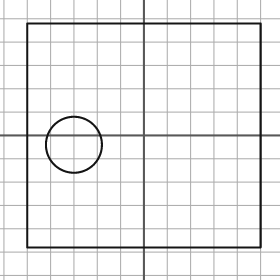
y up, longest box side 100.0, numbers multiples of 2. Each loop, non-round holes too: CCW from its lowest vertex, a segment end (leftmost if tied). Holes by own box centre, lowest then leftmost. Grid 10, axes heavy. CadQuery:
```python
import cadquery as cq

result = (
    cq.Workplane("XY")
    .moveTo(-50.0, -48.0)
    .lineTo(50.0, -48.0)
    .lineTo(50.0, 48.0)
    .lineTo(-50.0, 48.0)
    .close()
    .moveTo(-30.0, -4.0)
    .circle(12.0)
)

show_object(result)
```